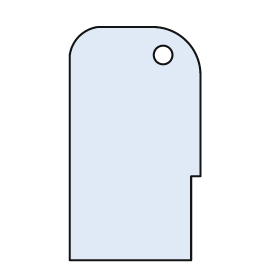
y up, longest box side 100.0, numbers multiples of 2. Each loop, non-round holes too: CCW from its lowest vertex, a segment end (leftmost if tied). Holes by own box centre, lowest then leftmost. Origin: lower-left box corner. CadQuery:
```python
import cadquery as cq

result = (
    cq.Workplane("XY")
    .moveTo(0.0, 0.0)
    .lineTo(52.0, 0.0)
    .lineTo(52.0, 36.0)
    .lineTo(56.0, 36.0)
    .lineTo(56.0, 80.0)
    .threePointArc((50.0, 94.0), (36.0, 100.0))
    .lineTo(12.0, 100.0)
    .threePointArc((4.0, 96.0), (0.0, 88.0))
    .close()
    .moveTo(40.0, 88.0)
    .circle(4.0)
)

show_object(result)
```